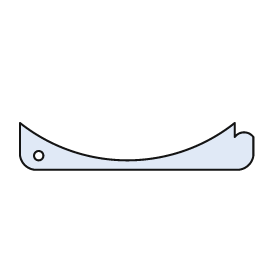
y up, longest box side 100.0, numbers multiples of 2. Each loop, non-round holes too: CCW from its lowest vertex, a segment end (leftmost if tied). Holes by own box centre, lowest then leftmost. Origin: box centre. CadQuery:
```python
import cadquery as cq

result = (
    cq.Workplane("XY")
    .moveTo(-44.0, -10.0)
    .lineTo(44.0, -10.0)
    .threePointArc((48.0, -8.0), (50.0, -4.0))
    .lineTo(50.0, 4.0)
    .threePointArc((46.0, 6.0), (42.0, 4.0))
    .lineTo(42.0, 10.0)
    .threePointArc((-4.0, -6.0), (-50.0, 10.0))
    .lineTo(-50.0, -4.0)
    .threePointArc((-48.0, -8.0), (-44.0, -10.0))
    .close()
    .moveTo(-42.0, -4.0)
    .circle(2.0)
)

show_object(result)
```